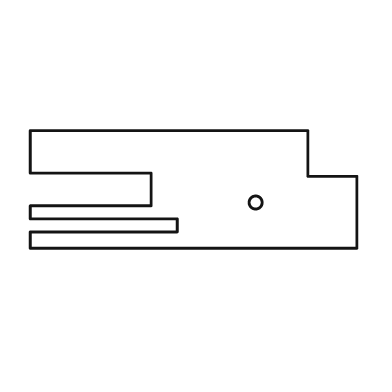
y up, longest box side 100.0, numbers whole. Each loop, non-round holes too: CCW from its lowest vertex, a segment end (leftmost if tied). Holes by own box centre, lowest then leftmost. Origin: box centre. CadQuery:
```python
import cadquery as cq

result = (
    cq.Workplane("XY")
    .moveTo(-50.0, -18.0)
    .lineTo(50.0, -18.0)
    .lineTo(50.0, 4.0)
    .lineTo(35.0, 4.0)
    .lineTo(35.0, 18.0)
    .lineTo(-50.0, 18.0)
    .lineTo(-50.0, 5.0)
    .lineTo(-13.0, 5.0)
    .lineTo(-13.0, -5.0)
    .lineTo(-50.0, -5.0)
    .lineTo(-50.0, -9.0)
    .lineTo(-5.0, -9.0)
    .lineTo(-5.0, -13.0)
    .lineTo(-50.0, -13.0)
    .close()
    .moveTo(19.0, -4.0)
    .circle(2.0)
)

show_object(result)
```